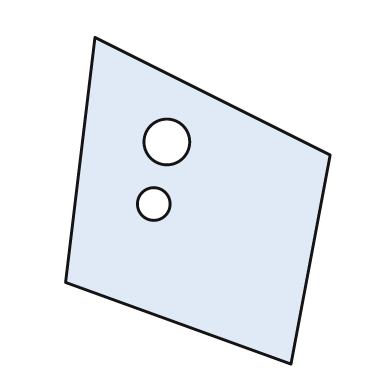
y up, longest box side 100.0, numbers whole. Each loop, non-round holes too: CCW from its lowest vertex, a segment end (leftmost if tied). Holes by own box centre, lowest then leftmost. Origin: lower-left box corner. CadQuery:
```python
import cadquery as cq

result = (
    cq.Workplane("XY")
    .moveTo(69.0, 0.0)
    .lineTo(81.0, 64.0)
    .lineTo(9.0, 100.0)
    .lineTo(0.0, 25.0)
    .close()
    .moveTo(27.0, 49.0)
    .circle(5.0)
    .moveTo(31.0, 68.0)
    .circle(7.0)
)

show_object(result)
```